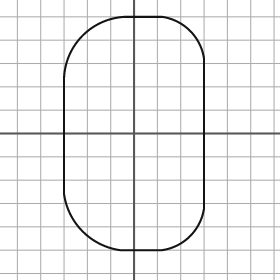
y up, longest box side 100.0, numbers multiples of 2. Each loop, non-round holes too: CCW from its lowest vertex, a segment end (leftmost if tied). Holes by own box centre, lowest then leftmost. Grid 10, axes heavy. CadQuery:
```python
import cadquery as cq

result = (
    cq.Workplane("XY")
    .moveTo(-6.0, -50.0)
    .lineTo(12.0, -50.0)
    .threePointArc((24.0, -44.0), (30.0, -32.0))
    .lineTo(30.0, 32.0)
    .threePointArc((24.0, 44.0), (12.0, 50.0))
    .lineTo(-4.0, 50.0)
    .threePointArc((-22.0, 42.0), (-30.0, 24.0))
    .lineTo(-30.0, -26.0)
    .threePointArc((-22.0, -42.0), (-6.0, -50.0))
    .close()
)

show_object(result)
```